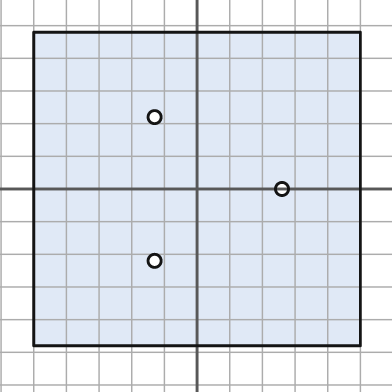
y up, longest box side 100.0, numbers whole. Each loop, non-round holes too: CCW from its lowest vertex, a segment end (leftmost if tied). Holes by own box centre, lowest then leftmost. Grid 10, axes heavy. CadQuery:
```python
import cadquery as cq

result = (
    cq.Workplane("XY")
    .moveTo(-50.0, -48.0)
    .lineTo(50.0, -48.0)
    .lineTo(50.0, 48.0)
    .lineTo(-50.0, 48.0)
    .close()
    .moveTo(-13.0, -22.0)
    .circle(2.0)
    .moveTo(26.0, 0.0)
    .circle(2.0)
    .moveTo(-13.0, 22.0)
    .circle(2.0)
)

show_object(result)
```